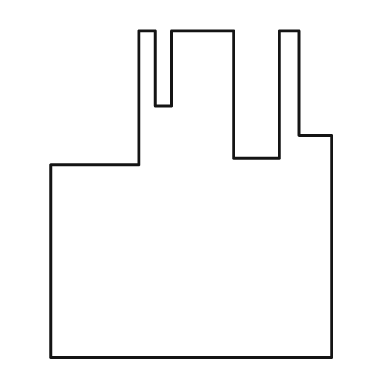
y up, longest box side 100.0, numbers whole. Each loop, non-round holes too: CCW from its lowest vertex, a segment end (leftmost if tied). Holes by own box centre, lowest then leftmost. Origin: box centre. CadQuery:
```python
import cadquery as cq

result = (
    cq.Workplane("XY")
    .moveTo(-43.0, -50.0)
    .lineTo(43.0, -50.0)
    .lineTo(43.0, 18.0)
    .lineTo(33.0, 18.0)
    .lineTo(33.0, 50.0)
    .lineTo(27.0, 50.0)
    .lineTo(27.0, 11.0)
    .lineTo(13.0, 11.0)
    .lineTo(13.0, 50.0)
    .lineTo(-6.0, 50.0)
    .lineTo(-6.0, 27.0)
    .lineTo(-11.0, 27.0)
    .lineTo(-11.0, 50.0)
    .lineTo(-16.0, 50.0)
    .lineTo(-16.0, 9.0)
    .lineTo(-43.0, 9.0)
    .close()
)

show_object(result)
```